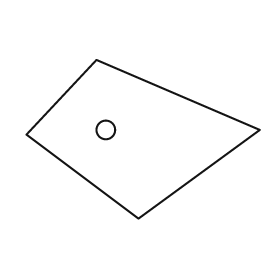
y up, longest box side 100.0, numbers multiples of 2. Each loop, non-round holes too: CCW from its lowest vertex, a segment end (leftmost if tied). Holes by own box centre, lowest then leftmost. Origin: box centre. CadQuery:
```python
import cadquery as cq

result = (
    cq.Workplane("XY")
    .moveTo(-2.0, -34.0)
    .lineTo(50.0, 4.0)
    .lineTo(-20.0, 34.0)
    .lineTo(-50.0, 2.0)
    .close()
    .moveTo(-16.0, 4.0)
    .circle(4.0)
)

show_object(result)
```